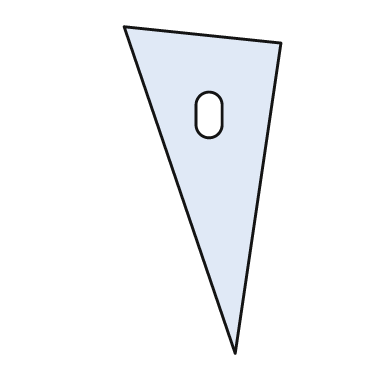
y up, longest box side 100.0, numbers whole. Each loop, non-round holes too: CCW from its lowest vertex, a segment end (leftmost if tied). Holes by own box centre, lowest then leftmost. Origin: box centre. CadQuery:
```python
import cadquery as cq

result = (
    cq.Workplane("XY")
    .moveTo(10.0, -50.0)
    .lineTo(24.0, 45.0)
    .lineTo(-24.0, 50.0)
    .close()
    .moveTo(-2.0, 20.0)
    .threePointArc((2.0, 16.0), (6.0, 20.0))
    .lineTo(6.0, 26.0)
    .threePointArc((2.0, 30.0), (-2.0, 26.0))
    .close()
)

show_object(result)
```